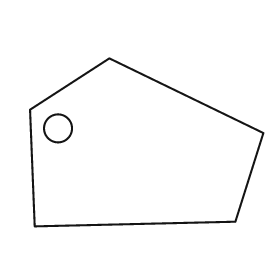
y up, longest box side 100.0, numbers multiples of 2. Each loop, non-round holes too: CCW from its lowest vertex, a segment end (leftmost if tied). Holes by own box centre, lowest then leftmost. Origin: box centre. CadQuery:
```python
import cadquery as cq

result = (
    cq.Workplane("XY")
    .moveTo(-48.0, -36.0)
    .lineTo(38.0, -34.0)
    .lineTo(50.0, 4.0)
    .lineTo(-16.0, 36.0)
    .lineTo(-50.0, 14.0)
    .close()
    .moveTo(-38.0, 6.0)
    .circle(6.0)
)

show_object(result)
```